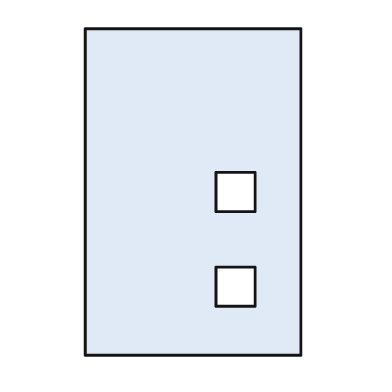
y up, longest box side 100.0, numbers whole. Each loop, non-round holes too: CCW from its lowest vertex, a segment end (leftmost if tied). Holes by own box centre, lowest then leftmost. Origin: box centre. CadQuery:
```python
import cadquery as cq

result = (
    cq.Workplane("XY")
    .moveTo(-33.0, -50.0)
    .lineTo(33.0, -50.0)
    .lineTo(33.0, 50.0)
    .lineTo(-33.0, 50.0)
    .close()
    .moveTo(7.0, -35.0)
    .lineTo(19.0, -35.0)
    .lineTo(19.0, -23.0)
    .lineTo(7.0, -23.0)
    .close()
    .moveTo(7.0, -6.0)
    .lineTo(19.0, -6.0)
    .lineTo(19.0, 6.0)
    .lineTo(7.0, 6.0)
    .close()
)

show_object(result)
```